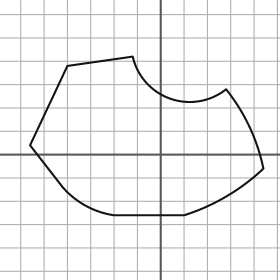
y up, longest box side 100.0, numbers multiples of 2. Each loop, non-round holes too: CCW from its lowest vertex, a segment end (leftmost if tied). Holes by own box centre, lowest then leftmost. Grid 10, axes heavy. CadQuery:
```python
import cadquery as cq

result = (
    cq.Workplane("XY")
    .moveTo(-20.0, -26.0)
    .lineTo(10.0, -26.0)
    .threePointArc((28.0, -18.0), (44.0, -6.0))
    .threePointArc((38.0, 12.0), (28.0, 28.0))
    .threePointArc((4.0, 24.0), (-12.0, 42.0))
    .lineTo(-40.0, 38.0)
    .lineTo(-56.0, 4.0)
    .lineTo(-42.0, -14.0)
    .threePointArc((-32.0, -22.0), (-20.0, -26.0))
    .close()
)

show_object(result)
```